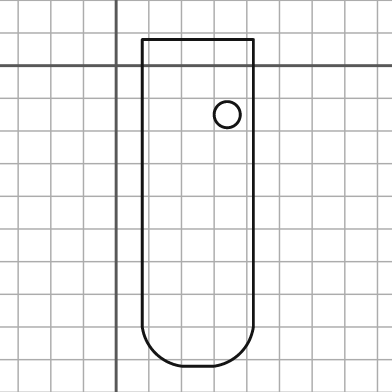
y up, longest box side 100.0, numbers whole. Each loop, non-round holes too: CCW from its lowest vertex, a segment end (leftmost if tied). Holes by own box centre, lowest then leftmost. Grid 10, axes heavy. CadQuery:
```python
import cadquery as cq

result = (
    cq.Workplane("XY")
    .moveTo(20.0, -92.0)
    .lineTo(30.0, -92.0)
    .threePointArc((38.0, -88.0), (42.0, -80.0))
    .lineTo(42.0, 8.0)
    .lineTo(8.0, 8.0)
    .lineTo(8.0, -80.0)
    .threePointArc((12.0, -88.0), (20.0, -92.0))
    .close()
    .moveTo(34.0, -15.0)
    .circle(4.0)
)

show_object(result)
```